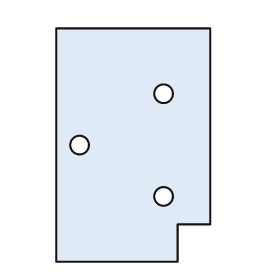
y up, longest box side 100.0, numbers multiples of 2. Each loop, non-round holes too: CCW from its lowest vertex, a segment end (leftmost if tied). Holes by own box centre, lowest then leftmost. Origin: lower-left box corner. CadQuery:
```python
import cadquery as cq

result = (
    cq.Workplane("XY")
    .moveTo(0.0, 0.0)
    .lineTo(52.0, 0.0)
    .lineTo(52.0, 16.0)
    .lineTo(66.0, 16.0)
    .lineTo(66.0, 100.0)
    .lineTo(0.0, 100.0)
    .close()
    .moveTo(46.0, 28.0)
    .circle(4.0)
    .moveTo(10.0, 50.0)
    .circle(4.0)
    .moveTo(46.0, 72.0)
    .circle(4.0)
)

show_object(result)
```